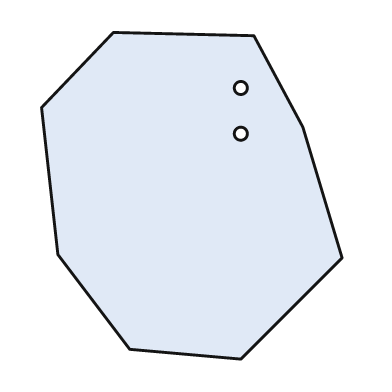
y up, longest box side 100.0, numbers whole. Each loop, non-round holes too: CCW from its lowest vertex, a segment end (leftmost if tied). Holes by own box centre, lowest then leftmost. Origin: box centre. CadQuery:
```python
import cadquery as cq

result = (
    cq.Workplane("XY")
    .moveTo(15.0, -50.0)
    .lineTo(46.0, -19.0)
    .lineTo(34.0, 21.0)
    .lineTo(19.0, 49.0)
    .lineTo(-24.0, 50.0)
    .lineTo(-46.0, 27.0)
    .lineTo(-41.0, -18.0)
    .lineTo(-19.0, -47.0)
    .close()
    .moveTo(15.0, 19.0)
    .circle(2.0)
    .moveTo(15.0, 33.0)
    .circle(2.0)
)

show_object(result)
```